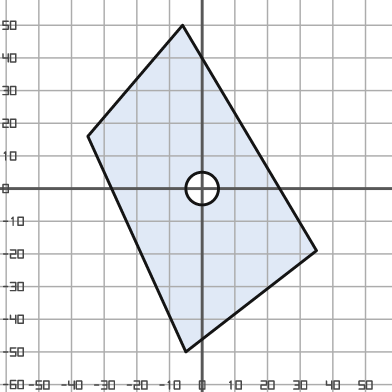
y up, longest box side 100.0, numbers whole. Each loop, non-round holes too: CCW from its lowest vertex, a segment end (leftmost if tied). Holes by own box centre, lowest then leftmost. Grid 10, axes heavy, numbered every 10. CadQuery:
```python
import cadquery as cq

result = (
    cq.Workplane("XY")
    .moveTo(-5.0, -50.0)
    .lineTo(35.0, -19.0)
    .lineTo(-6.0, 50.0)
    .lineTo(-35.0, 16.0)
    .close()
    .moveTo(0.0, 0.0)
    .circle(5.0)
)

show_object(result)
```